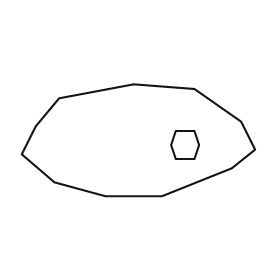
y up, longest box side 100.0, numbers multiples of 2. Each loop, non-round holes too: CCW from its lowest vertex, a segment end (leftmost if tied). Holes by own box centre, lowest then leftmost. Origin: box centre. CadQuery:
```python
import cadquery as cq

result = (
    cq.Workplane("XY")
    .moveTo(-14.0, -24.0)
    .lineTo(10.0, -24.0)
    .lineTo(40.0, -12.0)
    .lineTo(50.0, -4.0)
    .lineTo(44.0, 8.0)
    .lineTo(24.0, 22.0)
    .lineTo(-2.0, 24.0)
    .lineTo(-34.0, 18.0)
    .lineTo(-44.0, 6.0)
    .lineTo(-50.0, -6.0)
    .lineTo(-36.0, -18.0)
    .close()
    .moveTo(16.0, -8.0)
    .lineTo(24.0, -8.0)
    .lineTo(26.0, -2.0)
    .lineTo(24.0, 4.0)
    .lineTo(16.0, 4.0)
    .lineTo(14.0, -2.0)
    .close()
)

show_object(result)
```